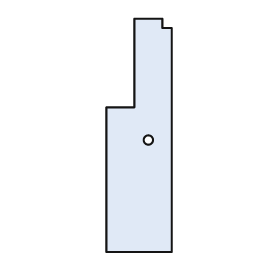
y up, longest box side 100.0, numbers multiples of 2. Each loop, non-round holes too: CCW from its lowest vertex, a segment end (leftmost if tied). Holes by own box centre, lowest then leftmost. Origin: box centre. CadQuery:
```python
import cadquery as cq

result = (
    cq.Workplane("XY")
    .moveTo(-14.0, -50.0)
    .lineTo(14.0, -50.0)
    .lineTo(14.0, 46.0)
    .lineTo(10.0, 46.0)
    .lineTo(10.0, 50.0)
    .lineTo(-2.0, 50.0)
    .lineTo(-2.0, 12.0)
    .lineTo(-14.0, 12.0)
    .close()
    .moveTo(4.0, -2.0)
    .circle(2.0)
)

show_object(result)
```